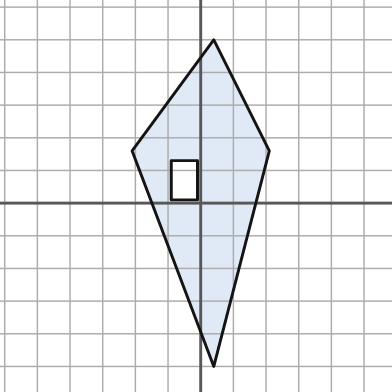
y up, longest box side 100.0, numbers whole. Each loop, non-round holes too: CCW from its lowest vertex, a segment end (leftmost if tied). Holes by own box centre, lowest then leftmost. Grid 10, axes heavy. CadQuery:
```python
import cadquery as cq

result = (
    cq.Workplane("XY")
    .moveTo(4.0, -50.0)
    .lineTo(21.0, 16.0)
    .lineTo(4.0, 50.0)
    .lineTo(-21.0, 16.0)
    .close()
    .moveTo(-9.0, 1.0)
    .lineTo(-1.0, 1.0)
    .lineTo(-1.0, 13.0)
    .lineTo(-9.0, 13.0)
    .close()
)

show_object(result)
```